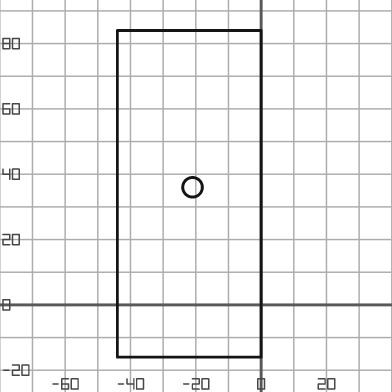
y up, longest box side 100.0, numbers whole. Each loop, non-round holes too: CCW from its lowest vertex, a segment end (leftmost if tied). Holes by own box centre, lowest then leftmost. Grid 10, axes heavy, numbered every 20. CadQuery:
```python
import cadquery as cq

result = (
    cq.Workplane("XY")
    .moveTo(-44.0, -16.0)
    .lineTo(0.0, -16.0)
    .lineTo(0.0, 84.0)
    .lineTo(-44.0, 84.0)
    .close()
    .moveTo(-21.0, 36.0)
    .circle(3.0)
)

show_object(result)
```